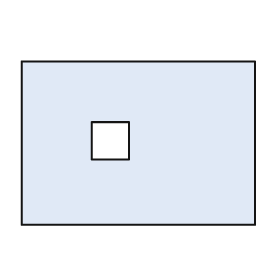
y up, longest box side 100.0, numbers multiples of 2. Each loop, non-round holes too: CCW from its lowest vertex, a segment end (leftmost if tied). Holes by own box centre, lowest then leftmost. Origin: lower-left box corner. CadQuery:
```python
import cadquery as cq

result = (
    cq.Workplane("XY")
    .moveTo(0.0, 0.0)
    .lineTo(100.0, 0.0)
    .lineTo(100.0, 70.0)
    .lineTo(0.0, 70.0)
    .close()
    .moveTo(30.0, 28.0)
    .lineTo(46.0, 28.0)
    .lineTo(46.0, 44.0)
    .lineTo(30.0, 44.0)
    .close()
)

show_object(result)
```